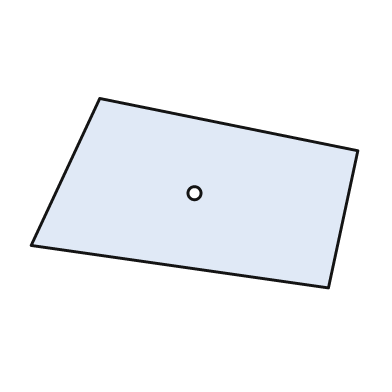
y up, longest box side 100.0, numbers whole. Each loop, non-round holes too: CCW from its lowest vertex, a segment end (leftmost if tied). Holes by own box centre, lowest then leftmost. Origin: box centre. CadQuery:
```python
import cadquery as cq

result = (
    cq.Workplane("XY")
    .moveTo(41.0, -29.0)
    .lineTo(50.0, 13.0)
    .lineTo(-29.0, 29.0)
    .lineTo(-50.0, -16.0)
    .close()
    .moveTo(0.0, 0.0)
    .circle(2.0)
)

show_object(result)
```